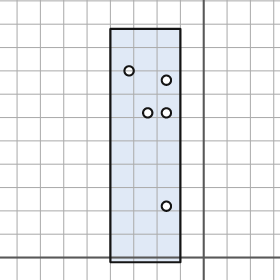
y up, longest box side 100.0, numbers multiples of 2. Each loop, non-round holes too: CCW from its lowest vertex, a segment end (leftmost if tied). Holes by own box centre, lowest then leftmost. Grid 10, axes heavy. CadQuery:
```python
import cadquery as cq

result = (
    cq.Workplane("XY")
    .moveTo(-40.0, -2.0)
    .lineTo(-10.0, -2.0)
    .lineTo(-10.0, 98.0)
    .lineTo(-40.0, 98.0)
    .close()
    .moveTo(-16.0, 22.0)
    .circle(2.0)
    .moveTo(-24.0, 62.0)
    .circle(2.0)
    .moveTo(-16.0, 62.0)
    .circle(2.0)
    .moveTo(-16.0, 76.0)
    .circle(2.0)
    .moveTo(-32.0, 80.0)
    .circle(2.0)
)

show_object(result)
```